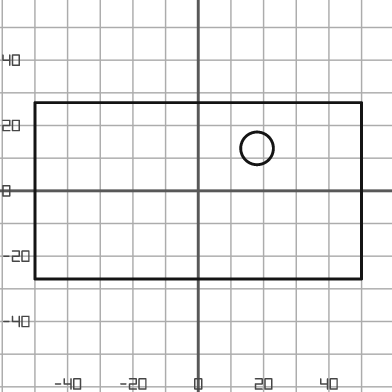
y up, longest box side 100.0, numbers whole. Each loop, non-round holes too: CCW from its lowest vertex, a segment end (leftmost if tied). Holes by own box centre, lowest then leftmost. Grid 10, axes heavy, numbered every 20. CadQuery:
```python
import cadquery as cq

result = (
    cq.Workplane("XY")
    .moveTo(-50.0, -27.0)
    .lineTo(50.0, -27.0)
    .lineTo(50.0, 27.0)
    .lineTo(-50.0, 27.0)
    .close()
    .moveTo(18.0, 13.0)
    .circle(5.0)
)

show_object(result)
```